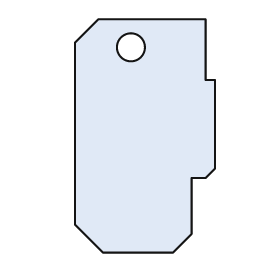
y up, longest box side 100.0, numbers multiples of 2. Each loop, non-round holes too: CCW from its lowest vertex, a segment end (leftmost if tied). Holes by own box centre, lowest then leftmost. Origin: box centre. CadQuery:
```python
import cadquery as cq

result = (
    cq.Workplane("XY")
    .moveTo(-18.0, -50.0)
    .lineTo(12.0, -50.0)
    .lineTo(20.0, -42.0)
    .lineTo(20.0, -18.0)
    .lineTo(26.0, -18.0)
    .lineTo(30.0, -14.0)
    .lineTo(30.0, 24.0)
    .lineTo(26.0, 24.0)
    .lineTo(26.0, 50.0)
    .lineTo(-20.0, 50.0)
    .lineTo(-30.0, 40.0)
    .lineTo(-30.0, -38.0)
    .close()
    .moveTo(-6.0, 38.0)
    .circle(6.0)
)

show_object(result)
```